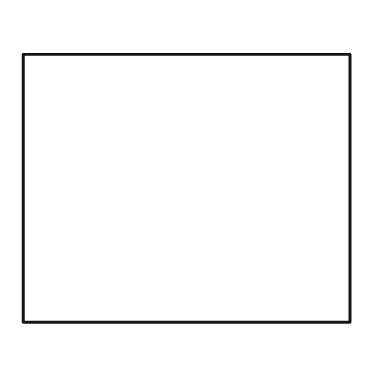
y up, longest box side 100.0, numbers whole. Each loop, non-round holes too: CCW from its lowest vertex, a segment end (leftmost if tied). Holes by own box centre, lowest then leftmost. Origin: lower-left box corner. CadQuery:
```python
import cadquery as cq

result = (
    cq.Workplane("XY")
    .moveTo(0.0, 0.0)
    .lineTo(100.0, 0.0)
    .lineTo(100.0, 82.0)
    .lineTo(0.0, 82.0)
    .close()
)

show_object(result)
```